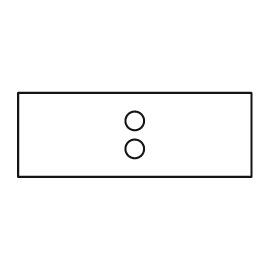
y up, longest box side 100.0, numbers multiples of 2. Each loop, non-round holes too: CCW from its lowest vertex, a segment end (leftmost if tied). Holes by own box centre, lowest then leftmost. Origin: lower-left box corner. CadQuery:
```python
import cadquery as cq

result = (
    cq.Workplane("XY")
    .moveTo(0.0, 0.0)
    .lineTo(100.0, 0.0)
    .lineTo(100.0, 36.0)
    .lineTo(0.0, 36.0)
    .close()
    .moveTo(50.0, 12.0)
    .circle(4.0)
    .moveTo(50.0, 24.0)
    .circle(4.0)
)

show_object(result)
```